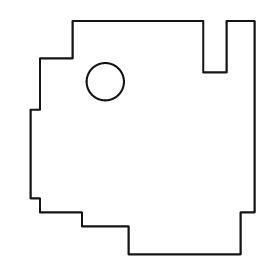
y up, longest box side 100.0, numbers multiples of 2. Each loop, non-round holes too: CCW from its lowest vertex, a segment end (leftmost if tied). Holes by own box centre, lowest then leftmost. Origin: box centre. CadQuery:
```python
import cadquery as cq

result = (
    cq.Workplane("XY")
    .moveTo(-6.0, -50.0)
    .lineTo(42.0, -50.0)
    .lineTo(42.0, -32.0)
    .lineTo(48.0, -32.0)
    .lineTo(48.0, 50.0)
    .lineTo(36.0, 50.0)
    .lineTo(36.0, 28.0)
    .lineTo(26.0, 28.0)
    .lineTo(26.0, 50.0)
    .lineTo(-30.0, 50.0)
    .lineTo(-30.0, 34.0)
    .lineTo(-44.0, 34.0)
    .lineTo(-44.0, 12.0)
    .lineTo(-48.0, 12.0)
    .lineTo(-48.0, -26.0)
    .lineTo(-44.0, -26.0)
    .lineTo(-44.0, -32.0)
    .lineTo(-26.0, -32.0)
    .lineTo(-26.0, -38.0)
    .lineTo(-6.0, -38.0)
    .close()
    .moveTo(-16.0, 24.0)
    .circle(8.0)
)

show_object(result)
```